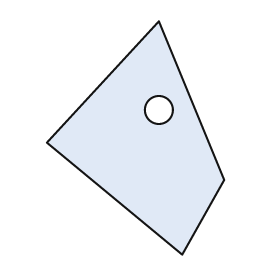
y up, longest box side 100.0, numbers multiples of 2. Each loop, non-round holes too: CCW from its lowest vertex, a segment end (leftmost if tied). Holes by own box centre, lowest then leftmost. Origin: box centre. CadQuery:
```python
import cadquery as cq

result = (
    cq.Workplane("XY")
    .moveTo(20.0, -50.0)
    .lineTo(38.0, -18.0)
    .lineTo(10.0, 50.0)
    .lineTo(-38.0, -2.0)
    .close()
    .moveTo(10.0, 12.0)
    .circle(6.0)
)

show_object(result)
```